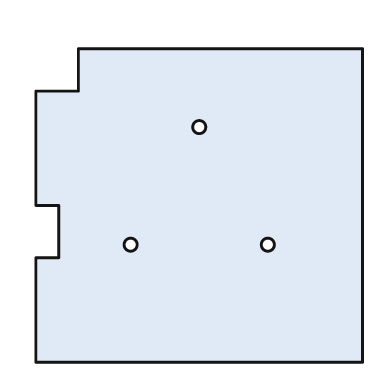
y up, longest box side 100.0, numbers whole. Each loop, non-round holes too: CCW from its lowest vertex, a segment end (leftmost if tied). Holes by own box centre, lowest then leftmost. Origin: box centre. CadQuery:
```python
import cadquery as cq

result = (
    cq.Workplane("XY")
    .moveTo(-50.0, -48.0)
    .lineTo(50.0, -48.0)
    .lineTo(50.0, 48.0)
    .lineTo(-37.0, 48.0)
    .lineTo(-37.0, 35.0)
    .lineTo(-50.0, 35.0)
    .lineTo(-50.0, 0.0)
    .lineTo(-43.0, 0.0)
    .lineTo(-43.0, -16.0)
    .lineTo(-50.0, -16.0)
    .close()
    .moveTo(-21.0, -12.0)
    .circle(2.0)
    .moveTo(21.0, -12.0)
    .circle(2.0)
    .moveTo(0.0, 24.0)
    .circle(2.0)
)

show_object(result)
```